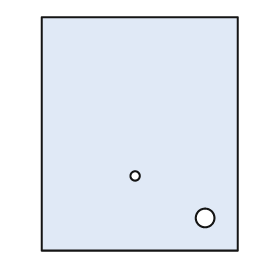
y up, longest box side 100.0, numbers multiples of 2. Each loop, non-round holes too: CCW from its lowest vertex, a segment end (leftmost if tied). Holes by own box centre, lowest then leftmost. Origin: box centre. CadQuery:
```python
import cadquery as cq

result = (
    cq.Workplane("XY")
    .moveTo(-42.0, -50.0)
    .lineTo(42.0, -50.0)
    .lineTo(42.0, 50.0)
    .lineTo(-42.0, 50.0)
    .close()
    .moveTo(28.0, -36.0)
    .circle(4.0)
    .moveTo(-2.0, -18.0)
    .circle(2.0)
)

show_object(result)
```